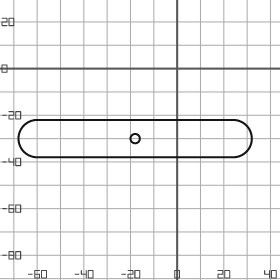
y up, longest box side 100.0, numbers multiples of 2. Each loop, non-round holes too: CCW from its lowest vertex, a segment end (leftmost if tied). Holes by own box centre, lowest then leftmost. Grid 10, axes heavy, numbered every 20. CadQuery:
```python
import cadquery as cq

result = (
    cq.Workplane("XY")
    .moveTo(-60.0, -38.0)
    .lineTo(24.0, -38.0)
    .threePointArc((32.0, -30.0), (24.0, -22.0))
    .lineTo(-60.0, -22.0)
    .threePointArc((-68.0, -30.0), (-60.0, -38.0))
    .close()
    .moveTo(-18.0, -30.0)
    .circle(2.0)
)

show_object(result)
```